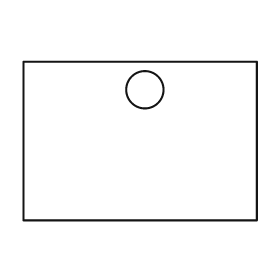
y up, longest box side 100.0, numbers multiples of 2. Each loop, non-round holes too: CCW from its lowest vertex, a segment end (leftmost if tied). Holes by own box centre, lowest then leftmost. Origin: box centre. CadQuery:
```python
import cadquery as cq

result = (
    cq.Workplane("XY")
    .moveTo(-50.0, -34.0)
    .lineTo(50.0, -34.0)
    .lineTo(50.0, 34.0)
    .lineTo(-50.0, 34.0)
    .close()
    .moveTo(2.0, 22.0)
    .circle(8.0)
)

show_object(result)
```